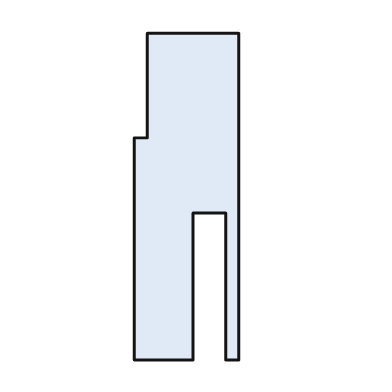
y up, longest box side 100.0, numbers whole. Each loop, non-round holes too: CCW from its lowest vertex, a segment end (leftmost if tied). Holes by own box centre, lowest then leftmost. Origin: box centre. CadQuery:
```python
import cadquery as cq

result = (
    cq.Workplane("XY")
    .moveTo(-16.0, -50.0)
    .lineTo(2.0, -50.0)
    .lineTo(2.0, -5.0)
    .lineTo(12.0, -5.0)
    .lineTo(12.0, -50.0)
    .lineTo(16.0, -50.0)
    .lineTo(16.0, 50.0)
    .lineTo(-12.0, 50.0)
    .lineTo(-12.0, 18.0)
    .lineTo(-16.0, 18.0)
    .close()
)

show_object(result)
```